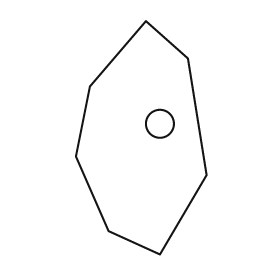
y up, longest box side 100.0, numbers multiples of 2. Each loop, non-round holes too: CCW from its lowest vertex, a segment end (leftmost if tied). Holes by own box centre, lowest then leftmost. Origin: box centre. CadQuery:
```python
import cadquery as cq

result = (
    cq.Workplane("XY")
    .moveTo(8.0, -50.0)
    .lineTo(28.0, -16.0)
    .lineTo(20.0, 34.0)
    .lineTo(2.0, 50.0)
    .lineTo(-22.0, 22.0)
    .lineTo(-28.0, -8.0)
    .lineTo(-14.0, -40.0)
    .close()
    .moveTo(8.0, 6.0)
    .circle(6.0)
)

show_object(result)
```